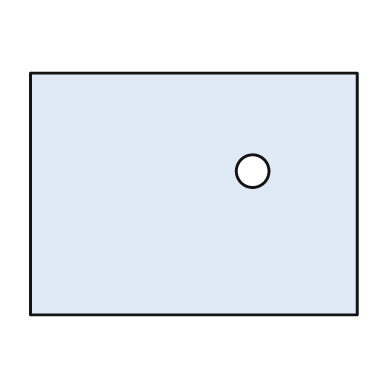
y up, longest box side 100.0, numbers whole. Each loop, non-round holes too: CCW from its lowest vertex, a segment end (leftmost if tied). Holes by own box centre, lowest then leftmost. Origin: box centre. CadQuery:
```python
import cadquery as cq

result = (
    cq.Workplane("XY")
    .moveTo(-50.0, -37.0)
    .lineTo(50.0, -37.0)
    .lineTo(50.0, 37.0)
    .lineTo(-50.0, 37.0)
    .close()
    .moveTo(18.0, 7.0)
    .circle(5.0)
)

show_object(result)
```